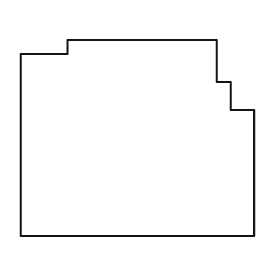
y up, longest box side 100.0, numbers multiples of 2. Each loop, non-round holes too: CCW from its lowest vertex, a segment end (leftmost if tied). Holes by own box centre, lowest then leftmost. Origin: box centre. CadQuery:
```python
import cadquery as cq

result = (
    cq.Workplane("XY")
    .moveTo(-50.0, -42.0)
    .lineTo(50.0, -42.0)
    .lineTo(50.0, 12.0)
    .lineTo(40.0, 12.0)
    .lineTo(40.0, 24.0)
    .lineTo(34.0, 24.0)
    .lineTo(34.0, 42.0)
    .lineTo(-30.0, 42.0)
    .lineTo(-30.0, 36.0)
    .lineTo(-50.0, 36.0)
    .close()
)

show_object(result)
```